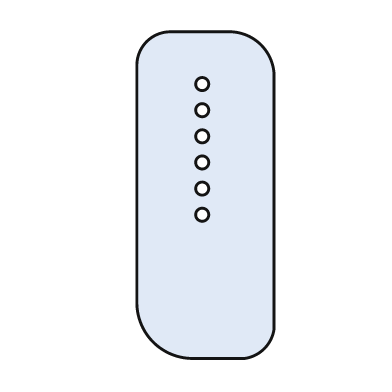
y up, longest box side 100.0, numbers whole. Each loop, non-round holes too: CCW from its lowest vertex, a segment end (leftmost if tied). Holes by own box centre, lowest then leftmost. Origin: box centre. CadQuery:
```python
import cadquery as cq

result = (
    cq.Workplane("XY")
    .moveTo(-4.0, -50.0)
    .lineTo(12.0, -50.0)
    .threePointArc((18.0, -47.0), (21.0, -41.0))
    .lineTo(21.0, 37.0)
    .threePointArc((17.0, 46.0), (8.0, 50.0))
    .lineTo(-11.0, 50.0)
    .threePointArc((-18.0, 47.0), (-21.0, 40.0))
    .lineTo(-21.0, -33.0)
    .threePointArc((-16.0, -45.0), (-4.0, -50.0))
    .close()
    .moveTo(-1.0, -6.0)
    .circle(2.0)
    .moveTo(-1.0, 2.0)
    .circle(2.0)
    .moveTo(-1.0, 10.0)
    .circle(2.0)
    .moveTo(-1.0, 18.0)
    .circle(2.0)
    .moveTo(-1.0, 26.0)
    .circle(2.0)
    .moveTo(-1.0, 34.0)
    .circle(2.0)
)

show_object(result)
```